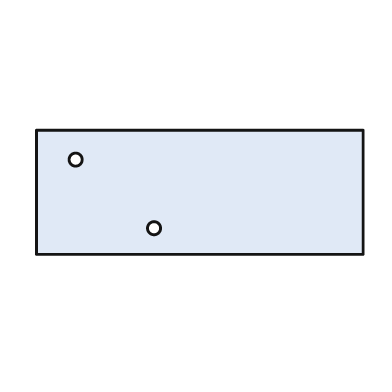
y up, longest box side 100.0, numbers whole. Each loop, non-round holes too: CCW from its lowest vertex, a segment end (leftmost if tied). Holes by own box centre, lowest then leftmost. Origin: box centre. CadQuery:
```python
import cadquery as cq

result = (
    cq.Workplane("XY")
    .moveTo(-50.0, -19.0)
    .lineTo(50.0, -19.0)
    .lineTo(50.0, 19.0)
    .lineTo(-50.0, 19.0)
    .close()
    .moveTo(-14.0, -11.0)
    .circle(2.0)
    .moveTo(-38.0, 10.0)
    .circle(2.0)
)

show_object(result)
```